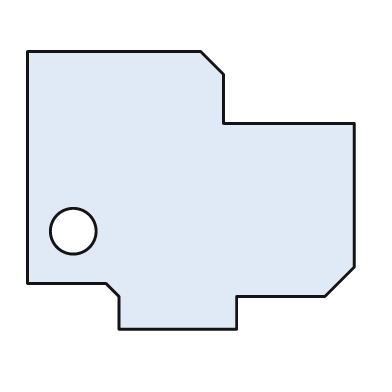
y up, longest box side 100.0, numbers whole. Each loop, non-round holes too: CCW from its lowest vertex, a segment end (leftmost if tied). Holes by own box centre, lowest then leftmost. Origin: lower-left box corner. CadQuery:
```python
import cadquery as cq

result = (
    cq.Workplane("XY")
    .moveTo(28.0, 0.0)
    .lineTo(64.0, 0.0)
    .lineTo(64.0, 10.0)
    .lineTo(91.0, 10.0)
    .lineTo(100.0, 19.0)
    .lineTo(100.0, 63.0)
    .lineTo(60.0, 63.0)
    .lineTo(60.0, 78.0)
    .lineTo(53.0, 85.0)
    .lineTo(0.0, 85.0)
    .lineTo(0.0, 14.0)
    .lineTo(24.0, 14.0)
    .lineTo(28.0, 10.0)
    .close()
    .moveTo(14.0, 30.0)
    .circle(7.0)
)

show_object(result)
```